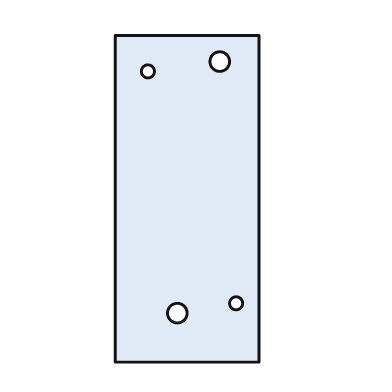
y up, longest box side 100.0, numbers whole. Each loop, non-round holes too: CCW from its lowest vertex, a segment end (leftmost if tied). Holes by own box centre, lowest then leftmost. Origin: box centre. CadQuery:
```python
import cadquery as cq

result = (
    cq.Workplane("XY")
    .moveTo(-22.0, -50.0)
    .lineTo(22.0, -50.0)
    .lineTo(22.0, 50.0)
    .lineTo(-22.0, 50.0)
    .close()
    .moveTo(-3.0, -35.0)
    .circle(3.0)
    .moveTo(15.0, -32.0)
    .circle(2.0)
    .moveTo(-12.0, 39.0)
    .circle(2.0)
    .moveTo(10.0, 42.0)
    .circle(3.0)
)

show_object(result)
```